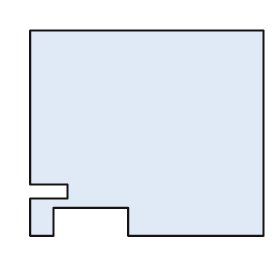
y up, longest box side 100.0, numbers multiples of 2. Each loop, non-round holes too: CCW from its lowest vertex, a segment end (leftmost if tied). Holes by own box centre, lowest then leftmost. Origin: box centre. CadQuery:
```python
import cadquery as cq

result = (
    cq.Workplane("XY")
    .moveTo(-50.0, -44.0)
    .lineTo(-40.0, -44.0)
    .lineTo(-40.0, -32.0)
    .lineTo(-8.0, -32.0)
    .lineTo(-8.0, -44.0)
    .lineTo(50.0, -44.0)
    .lineTo(50.0, 44.0)
    .lineTo(-50.0, 44.0)
    .lineTo(-50.0, -22.0)
    .lineTo(-34.0, -22.0)
    .lineTo(-34.0, -28.0)
    .lineTo(-50.0, -28.0)
    .close()
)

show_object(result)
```